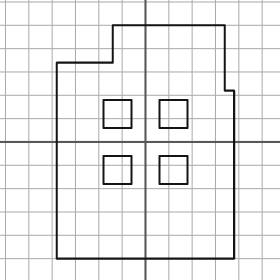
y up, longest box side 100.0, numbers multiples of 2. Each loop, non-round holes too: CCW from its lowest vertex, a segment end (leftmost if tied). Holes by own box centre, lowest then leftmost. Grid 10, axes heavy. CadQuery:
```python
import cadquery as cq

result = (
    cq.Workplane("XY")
    .moveTo(-38.0, -50.0)
    .lineTo(38.0, -50.0)
    .lineTo(38.0, 22.0)
    .lineTo(34.0, 22.0)
    .lineTo(34.0, 50.0)
    .lineTo(-14.0, 50.0)
    .lineTo(-14.0, 34.0)
    .lineTo(-38.0, 34.0)
    .close()
    .moveTo(-18.0, -18.0)
    .lineTo(-6.0, -18.0)
    .lineTo(-6.0, -6.0)
    .lineTo(-18.0, -6.0)
    .close()
    .moveTo(6.0, -18.0)
    .lineTo(18.0, -18.0)
    .lineTo(18.0, -6.0)
    .lineTo(6.0, -6.0)
    .close()
    .moveTo(-18.0, 6.0)
    .lineTo(-6.0, 6.0)
    .lineTo(-6.0, 18.0)
    .lineTo(-18.0, 18.0)
    .close()
    .moveTo(6.0, 6.0)
    .lineTo(18.0, 6.0)
    .lineTo(18.0, 18.0)
    .lineTo(6.0, 18.0)
    .close()
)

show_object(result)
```